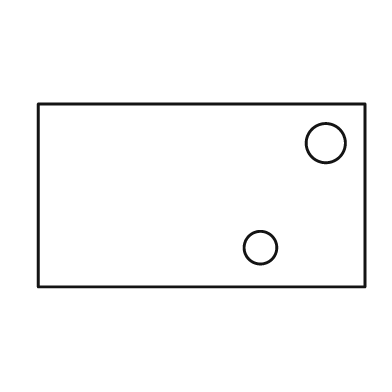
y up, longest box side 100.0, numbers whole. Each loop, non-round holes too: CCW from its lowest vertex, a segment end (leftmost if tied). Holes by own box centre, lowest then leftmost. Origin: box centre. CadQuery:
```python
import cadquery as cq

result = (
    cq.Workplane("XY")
    .moveTo(-50.0, -28.0)
    .lineTo(50.0, -28.0)
    .lineTo(50.0, 28.0)
    .lineTo(-50.0, 28.0)
    .close()
    .moveTo(18.0, -16.0)
    .circle(5.0)
    .moveTo(38.0, 16.0)
    .circle(6.0)
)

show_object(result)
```